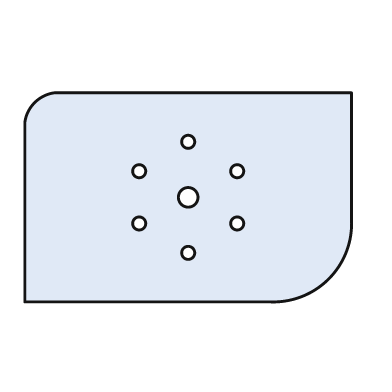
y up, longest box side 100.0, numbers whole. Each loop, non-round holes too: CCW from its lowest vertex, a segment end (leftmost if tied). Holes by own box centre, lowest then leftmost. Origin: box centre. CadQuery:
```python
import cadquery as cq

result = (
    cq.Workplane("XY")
    .moveTo(-50.0, -32.0)
    .lineTo(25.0, -32.0)
    .threePointArc((43.0, -25.0), (50.0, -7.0))
    .lineTo(50.0, 32.0)
    .lineTo(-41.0, 32.0)
    .threePointArc((-47.0, 29.0), (-50.0, 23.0))
    .close()
    .moveTo(0.0, -17.0)
    .circle(2.0)
    .moveTo(-15.0, -8.0)
    .circle(2.0)
    .moveTo(15.0, -8.0)
    .circle(2.0)
    .moveTo(0.0, 0.0)
    .circle(3.0)
    .moveTo(-15.0, 8.0)
    .circle(2.0)
    .moveTo(15.0, 8.0)
    .circle(2.0)
    .moveTo(0.0, 17.0)
    .circle(2.0)
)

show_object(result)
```